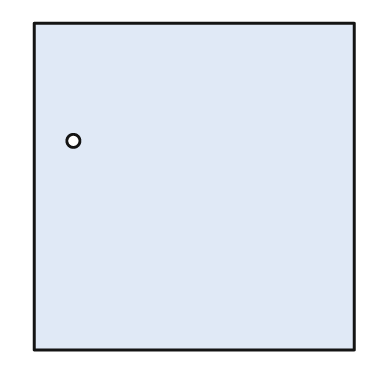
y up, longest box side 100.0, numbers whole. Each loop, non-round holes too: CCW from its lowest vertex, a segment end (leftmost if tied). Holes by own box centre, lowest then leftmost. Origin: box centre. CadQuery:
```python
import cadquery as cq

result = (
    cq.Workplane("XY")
    .moveTo(-49.0, -50.0)
    .lineTo(49.0, -50.0)
    .lineTo(49.0, 50.0)
    .lineTo(-49.0, 50.0)
    .close()
    .moveTo(-37.0, 14.0)
    .circle(2.0)
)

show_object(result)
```